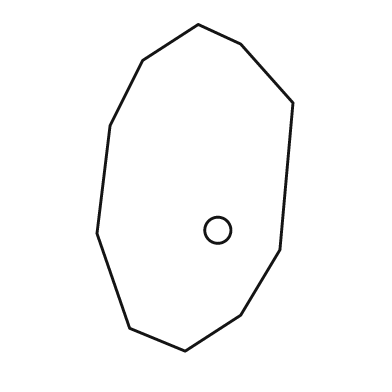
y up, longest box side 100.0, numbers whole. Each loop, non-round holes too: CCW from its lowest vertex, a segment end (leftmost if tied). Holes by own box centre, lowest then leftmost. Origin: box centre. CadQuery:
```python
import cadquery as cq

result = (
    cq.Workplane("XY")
    .moveTo(-3.0, -50.0)
    .lineTo(14.0, -39.0)
    .lineTo(26.0, -19.0)
    .lineTo(30.0, 26.0)
    .lineTo(14.0, 44.0)
    .lineTo(1.0, 50.0)
    .lineTo(-16.0, 39.0)
    .lineTo(-26.0, 19.0)
    .lineTo(-30.0, -14.0)
    .lineTo(-20.0, -43.0)
    .close()
    .moveTo(7.0, -13.0)
    .circle(4.0)
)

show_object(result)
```